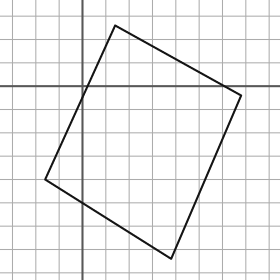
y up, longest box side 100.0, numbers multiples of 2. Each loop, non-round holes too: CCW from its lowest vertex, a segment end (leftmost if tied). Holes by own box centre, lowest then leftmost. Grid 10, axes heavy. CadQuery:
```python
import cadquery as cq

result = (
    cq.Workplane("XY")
    .moveTo(38.0, -74.0)
    .lineTo(68.0, -4.0)
    .lineTo(14.0, 26.0)
    .lineTo(-16.0, -40.0)
    .close()
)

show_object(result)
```